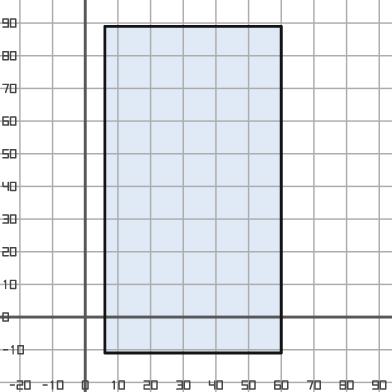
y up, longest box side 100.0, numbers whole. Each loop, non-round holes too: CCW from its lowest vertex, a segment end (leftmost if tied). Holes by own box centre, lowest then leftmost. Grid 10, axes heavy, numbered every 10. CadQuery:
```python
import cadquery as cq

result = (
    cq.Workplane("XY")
    .moveTo(6.0, -11.0)
    .lineTo(60.0, -11.0)
    .lineTo(60.0, 89.0)
    .lineTo(6.0, 89.0)
    .close()
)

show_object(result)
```